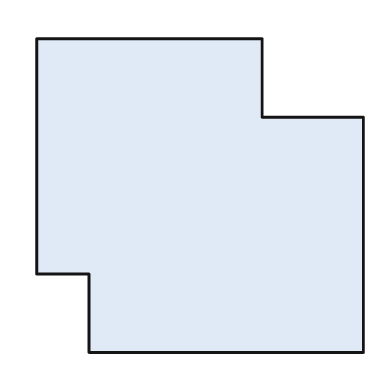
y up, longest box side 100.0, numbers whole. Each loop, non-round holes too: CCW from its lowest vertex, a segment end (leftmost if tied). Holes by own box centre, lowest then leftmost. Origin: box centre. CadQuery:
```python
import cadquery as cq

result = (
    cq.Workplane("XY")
    .moveTo(-34.0, -48.0)
    .lineTo(50.0, -48.0)
    .lineTo(50.0, 24.0)
    .lineTo(19.0, 24.0)
    .lineTo(19.0, 48.0)
    .lineTo(-50.0, 48.0)
    .lineTo(-50.0, -24.0)
    .lineTo(-34.0, -24.0)
    .close()
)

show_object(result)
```